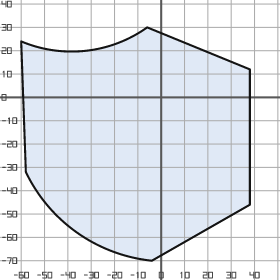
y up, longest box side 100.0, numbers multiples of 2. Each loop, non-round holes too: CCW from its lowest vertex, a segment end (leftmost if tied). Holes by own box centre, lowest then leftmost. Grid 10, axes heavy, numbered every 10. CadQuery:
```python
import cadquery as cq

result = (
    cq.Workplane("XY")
    .moveTo(-4.0, -70.0)
    .lineTo(38.0, -46.0)
    .lineTo(38.0, 12.0)
    .lineTo(-6.0, 30.0)
    .threePointArc((-32.0, 20.0), (-60.0, 24.0))
    .lineTo(-58.0, -32.0)
    .threePointArc((-36.0, -58.0), (-4.0, -70.0))
    .close()
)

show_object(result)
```